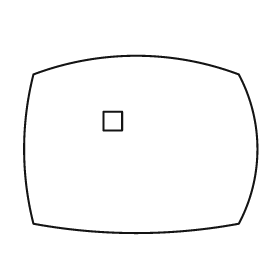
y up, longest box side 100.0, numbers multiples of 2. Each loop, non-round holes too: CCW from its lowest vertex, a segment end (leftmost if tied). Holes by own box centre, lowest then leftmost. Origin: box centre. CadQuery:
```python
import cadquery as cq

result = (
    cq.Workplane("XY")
    .moveTo(-46.0, -34.0)
    .threePointArc((-2.0, -38.0), (42.0, -34.0))
    .threePointArc((50.0, -2.0), (42.0, 30.0))
    .threePointArc((-2.0, 38.0), (-46.0, 30.0))
    .threePointArc((-50.0, -2.0), (-46.0, -34.0))
    .close()
    .moveTo(-16.0, 6.0)
    .lineTo(-8.0, 6.0)
    .lineTo(-8.0, 14.0)
    .lineTo(-16.0, 14.0)
    .close()
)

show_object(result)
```